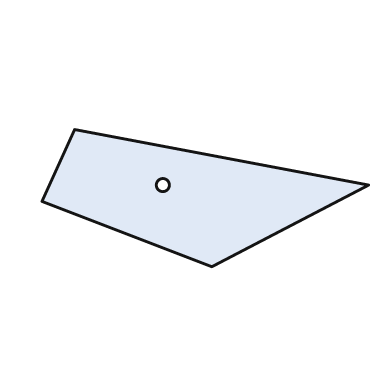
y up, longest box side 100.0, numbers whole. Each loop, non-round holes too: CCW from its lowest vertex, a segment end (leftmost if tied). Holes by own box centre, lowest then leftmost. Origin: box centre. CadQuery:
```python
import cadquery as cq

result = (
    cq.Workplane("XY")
    .moveTo(2.0, -21.0)
    .lineTo(50.0, 4.0)
    .lineTo(-40.0, 21.0)
    .lineTo(-50.0, -1.0)
    .close()
    .moveTo(-13.0, 4.0)
    .circle(2.0)
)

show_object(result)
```